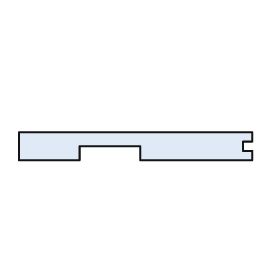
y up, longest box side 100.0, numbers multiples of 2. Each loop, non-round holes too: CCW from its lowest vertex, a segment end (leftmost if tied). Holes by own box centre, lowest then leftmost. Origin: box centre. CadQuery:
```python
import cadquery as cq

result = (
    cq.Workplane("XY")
    .moveTo(-50.0, -6.0)
    .lineTo(-24.0, -6.0)
    .lineTo(-24.0, 0.0)
    .lineTo(2.0, 0.0)
    .lineTo(2.0, -6.0)
    .lineTo(50.0, -6.0)
    .lineTo(50.0, -2.0)
    .lineTo(46.0, -2.0)
    .lineTo(46.0, 2.0)
    .lineTo(50.0, 2.0)
    .lineTo(50.0, 6.0)
    .lineTo(-50.0, 6.0)
    .close()
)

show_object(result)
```